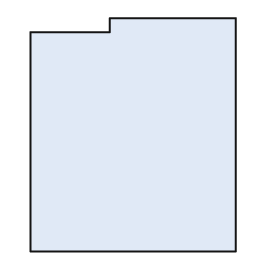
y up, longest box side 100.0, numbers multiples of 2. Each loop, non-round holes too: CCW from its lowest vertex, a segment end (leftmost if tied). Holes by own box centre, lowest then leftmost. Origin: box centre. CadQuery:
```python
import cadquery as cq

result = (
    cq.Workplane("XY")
    .moveTo(-44.0, -50.0)
    .lineTo(44.0, -50.0)
    .lineTo(44.0, 50.0)
    .lineTo(-10.0, 50.0)
    .lineTo(-10.0, 44.0)
    .lineTo(-44.0, 44.0)
    .close()
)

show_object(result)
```